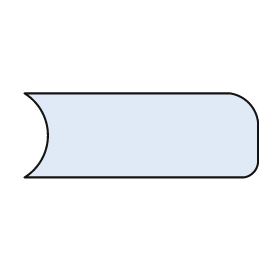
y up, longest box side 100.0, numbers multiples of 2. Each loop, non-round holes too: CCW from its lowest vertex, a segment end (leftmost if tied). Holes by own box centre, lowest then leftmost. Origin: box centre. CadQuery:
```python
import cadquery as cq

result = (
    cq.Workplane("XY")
    .moveTo(-50.0, -18.0)
    .lineTo(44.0, -18.0)
    .threePointArc((48.0, -16.0), (50.0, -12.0))
    .lineTo(50.0, 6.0)
    .threePointArc((46.0, 14.0), (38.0, 18.0))
    .lineTo(-50.0, 18.0)
    .threePointArc((-40.0, 0.0), (-50.0, -18.0))
    .close()
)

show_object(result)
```